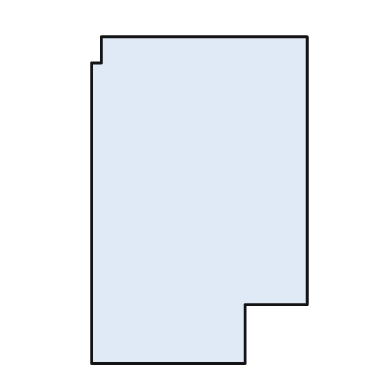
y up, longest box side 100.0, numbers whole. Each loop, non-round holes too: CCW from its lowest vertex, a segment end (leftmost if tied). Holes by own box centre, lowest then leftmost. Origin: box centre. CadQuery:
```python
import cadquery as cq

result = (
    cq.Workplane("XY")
    .moveTo(-33.0, -50.0)
    .lineTo(14.0, -50.0)
    .lineTo(14.0, -32.0)
    .lineTo(33.0, -32.0)
    .lineTo(33.0, 50.0)
    .lineTo(-30.0, 50.0)
    .lineTo(-30.0, 42.0)
    .lineTo(-33.0, 42.0)
    .close()
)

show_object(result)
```